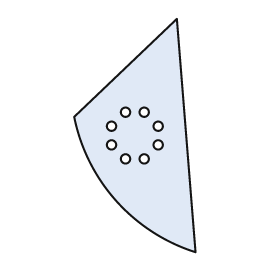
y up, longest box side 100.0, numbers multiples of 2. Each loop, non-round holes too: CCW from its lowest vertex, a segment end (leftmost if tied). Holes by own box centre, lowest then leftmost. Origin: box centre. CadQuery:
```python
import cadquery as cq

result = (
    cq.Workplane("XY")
    .moveTo(26.0, -50.0)
    .lineTo(18.0, 50.0)
    .lineTo(-26.0, 8.0)
    .threePointArc((-8.0, -28.0), (26.0, -50.0))
    .close()
    .moveTo(-4.0, -10.0)
    .circle(2.0)
    .moveTo(4.0, -10.0)
    .circle(2.0)
    .moveTo(-10.0, -4.0)
    .circle(2.0)
    .moveTo(10.0, -4.0)
    .circle(2.0)
    .moveTo(-10.0, 4.0)
    .circle(2.0)
    .moveTo(10.0, 4.0)
    .circle(2.0)
    .moveTo(-4.0, 10.0)
    .circle(2.0)
    .moveTo(4.0, 10.0)
    .circle(2.0)
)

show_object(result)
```